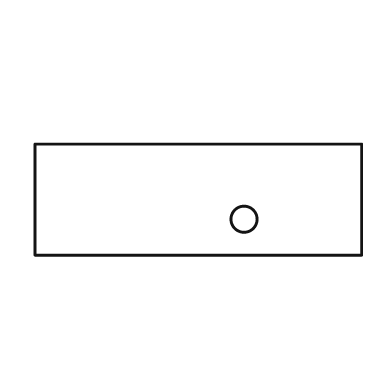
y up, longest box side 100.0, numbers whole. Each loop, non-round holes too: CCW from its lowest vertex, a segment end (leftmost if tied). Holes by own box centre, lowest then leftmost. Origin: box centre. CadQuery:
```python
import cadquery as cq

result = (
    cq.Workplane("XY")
    .moveTo(-50.0, -17.0)
    .lineTo(50.0, -17.0)
    .lineTo(50.0, 17.0)
    .lineTo(-50.0, 17.0)
    .close()
    .moveTo(14.0, -6.0)
    .circle(4.0)
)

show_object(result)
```